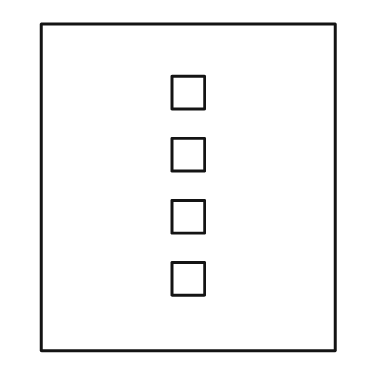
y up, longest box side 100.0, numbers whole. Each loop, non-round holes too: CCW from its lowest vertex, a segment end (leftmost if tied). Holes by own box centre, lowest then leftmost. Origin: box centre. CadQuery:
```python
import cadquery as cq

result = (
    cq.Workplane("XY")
    .moveTo(-45.0, -50.0)
    .lineTo(45.0, -50.0)
    .lineTo(45.0, 50.0)
    .lineTo(-45.0, 50.0)
    .close()
    .moveTo(-5.0, -33.0)
    .lineTo(5.0, -33.0)
    .lineTo(5.0, -23.0)
    .lineTo(-5.0, -23.0)
    .close()
    .moveTo(-5.0, -14.0)
    .lineTo(5.0, -14.0)
    .lineTo(5.0, -4.0)
    .lineTo(-5.0, -4.0)
    .close()
    .moveTo(-5.0, 5.0)
    .lineTo(5.0, 5.0)
    .lineTo(5.0, 15.0)
    .lineTo(-5.0, 15.0)
    .close()
    .moveTo(-5.0, 24.0)
    .lineTo(5.0, 24.0)
    .lineTo(5.0, 34.0)
    .lineTo(-5.0, 34.0)
    .close()
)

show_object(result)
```